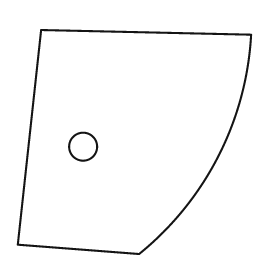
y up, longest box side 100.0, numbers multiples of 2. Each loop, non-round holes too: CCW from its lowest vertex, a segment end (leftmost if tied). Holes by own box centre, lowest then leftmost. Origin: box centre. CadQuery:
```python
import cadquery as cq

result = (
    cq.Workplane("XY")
    .moveTo(2.0, -48.0)
    .threePointArc((36.0, -6.0), (50.0, 46.0))
    .lineTo(-40.0, 48.0)
    .lineTo(-50.0, -44.0)
    .close()
    .moveTo(-22.0, -2.0)
    .circle(6.0)
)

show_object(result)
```